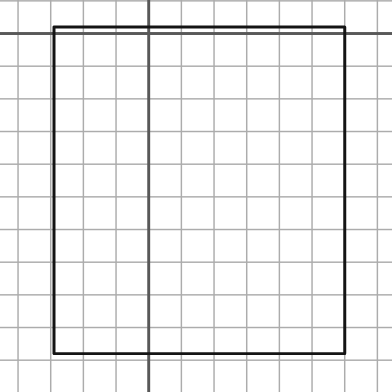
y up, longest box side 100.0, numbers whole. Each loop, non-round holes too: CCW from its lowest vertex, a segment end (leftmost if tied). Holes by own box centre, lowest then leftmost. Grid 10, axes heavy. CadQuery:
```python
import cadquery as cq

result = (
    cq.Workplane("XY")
    .moveTo(-29.0, -98.0)
    .lineTo(60.0, -98.0)
    .lineTo(60.0, 2.0)
    .lineTo(-29.0, 2.0)
    .close()
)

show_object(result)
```